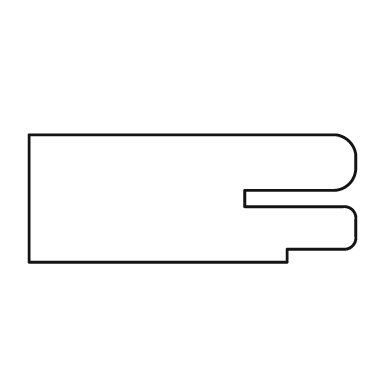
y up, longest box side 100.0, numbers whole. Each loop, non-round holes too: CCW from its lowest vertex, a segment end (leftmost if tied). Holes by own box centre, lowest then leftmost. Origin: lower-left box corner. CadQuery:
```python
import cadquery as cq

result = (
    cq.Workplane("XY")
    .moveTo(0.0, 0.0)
    .lineTo(79.0, 0.0)
    .lineTo(79.0, 4.0)
    .lineTo(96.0, 4.0)
    .threePointArc((99.0, 5.0), (100.0, 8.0))
    .lineTo(100.0, 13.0)
    .threePointArc((99.0, 16.0), (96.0, 17.0))
    .lineTo(66.0, 17.0)
    .lineTo(66.0, 22.0)
    .lineTo(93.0, 22.0)
    .threePointArc((98.0, 24.0), (100.0, 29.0))
    .lineTo(100.0, 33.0)
    .threePointArc((98.0, 37.0), (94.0, 39.0))
    .lineTo(0.0, 39.0)
    .close()
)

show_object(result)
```